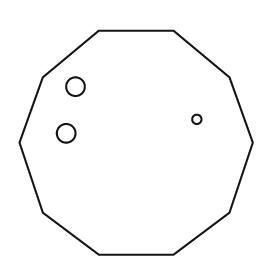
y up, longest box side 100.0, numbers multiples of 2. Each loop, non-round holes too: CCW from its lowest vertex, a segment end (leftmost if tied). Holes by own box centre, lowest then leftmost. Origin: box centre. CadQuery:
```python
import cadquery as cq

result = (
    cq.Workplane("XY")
    .moveTo(-16.0, -48.0)
    .lineTo(16.0, -48.0)
    .lineTo(40.0, -30.0)
    .lineTo(50.0, 0.0)
    .lineTo(40.0, 28.0)
    .lineTo(16.0, 48.0)
    .lineTo(-16.0, 48.0)
    .lineTo(-40.0, 28.0)
    .lineTo(-50.0, 0.0)
    .lineTo(-40.0, -30.0)
    .close()
    .moveTo(-30.0, 4.0)
    .circle(4.0)
    .moveTo(26.0, 10.0)
    .circle(2.0)
    .moveTo(-26.0, 24.0)
    .circle(4.0)
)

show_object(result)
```